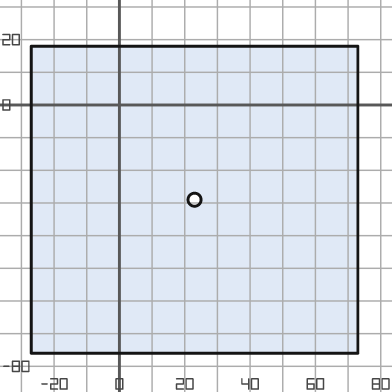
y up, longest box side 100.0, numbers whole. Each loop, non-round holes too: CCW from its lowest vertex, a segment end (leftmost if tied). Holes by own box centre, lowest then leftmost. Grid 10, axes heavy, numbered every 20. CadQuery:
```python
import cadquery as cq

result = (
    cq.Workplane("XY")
    .moveTo(-27.0, -76.0)
    .lineTo(73.0, -76.0)
    .lineTo(73.0, 18.0)
    .lineTo(-27.0, 18.0)
    .close()
    .moveTo(23.0, -29.0)
    .circle(2.0)
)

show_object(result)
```